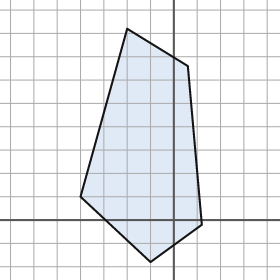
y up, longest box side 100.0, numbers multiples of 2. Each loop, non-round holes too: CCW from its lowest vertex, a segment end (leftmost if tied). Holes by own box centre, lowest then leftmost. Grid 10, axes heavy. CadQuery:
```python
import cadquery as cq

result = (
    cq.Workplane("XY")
    .moveTo(-10.0, -18.0)
    .lineTo(12.0, -2.0)
    .lineTo(6.0, 66.0)
    .lineTo(-20.0, 82.0)
    .lineTo(-40.0, 10.0)
    .close()
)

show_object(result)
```